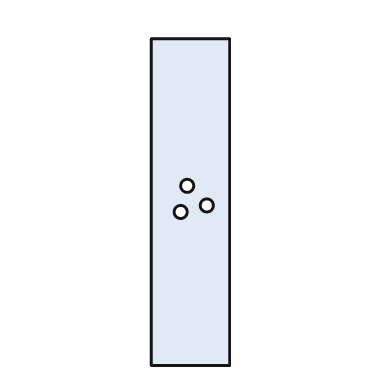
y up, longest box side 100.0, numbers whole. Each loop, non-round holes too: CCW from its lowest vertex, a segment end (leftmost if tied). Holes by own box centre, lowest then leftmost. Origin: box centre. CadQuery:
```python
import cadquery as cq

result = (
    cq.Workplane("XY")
    .moveTo(-12.0, -50.0)
    .lineTo(12.0, -50.0)
    .lineTo(12.0, 50.0)
    .lineTo(-12.0, 50.0)
    .close()
    .moveTo(-3.0, -3.0)
    .circle(2.0)
    .moveTo(5.0, -1.0)
    .circle(2.0)
    .moveTo(-1.0, 5.0)
    .circle(2.0)
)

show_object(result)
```